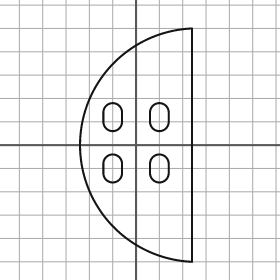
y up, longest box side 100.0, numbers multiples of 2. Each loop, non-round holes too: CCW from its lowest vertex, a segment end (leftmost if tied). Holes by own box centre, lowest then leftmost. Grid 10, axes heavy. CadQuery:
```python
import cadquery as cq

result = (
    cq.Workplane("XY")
    .moveTo(24.0, -50.0)
    .lineTo(24.0, 50.0)
    .threePointArc((-24.0, 0.0), (24.0, -50.0))
    .close()
    .moveTo(-14.0, -12.0)
    .threePointArc((-10.0, -16.0), (-6.0, -12.0))
    .lineTo(-6.0, -8.0)
    .threePointArc((-10.0, -4.0), (-14.0, -8.0))
    .close()
    .moveTo(6.0, -12.0)
    .threePointArc((10.0, -16.0), (14.0, -12.0))
    .lineTo(14.0, -8.0)
    .threePointArc((10.0, -4.0), (6.0, -8.0))
    .close()
    .moveTo(-14.0, 10.0)
    .threePointArc((-10.0, 6.0), (-6.0, 10.0))
    .lineTo(-6.0, 14.0)
    .threePointArc((-10.0, 18.0), (-14.0, 14.0))
    .close()
    .moveTo(6.0, 10.0)
    .threePointArc((10.0, 6.0), (14.0, 10.0))
    .lineTo(14.0, 14.0)
    .threePointArc((10.0, 18.0), (6.0, 14.0))
    .close()
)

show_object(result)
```